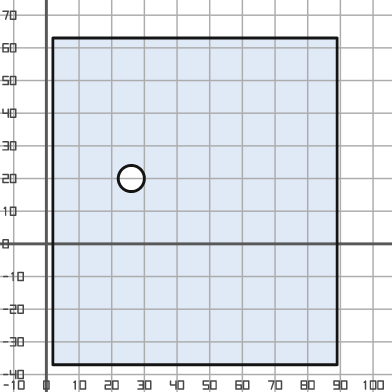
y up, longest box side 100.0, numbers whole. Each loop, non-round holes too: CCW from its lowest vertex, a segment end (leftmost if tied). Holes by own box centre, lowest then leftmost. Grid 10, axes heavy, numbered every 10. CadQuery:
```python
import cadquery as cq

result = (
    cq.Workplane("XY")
    .moveTo(2.0, -37.0)
    .lineTo(89.0, -37.0)
    .lineTo(89.0, 63.0)
    .lineTo(2.0, 63.0)
    .close()
    .moveTo(26.0, 20.0)
    .circle(4.0)
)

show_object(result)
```